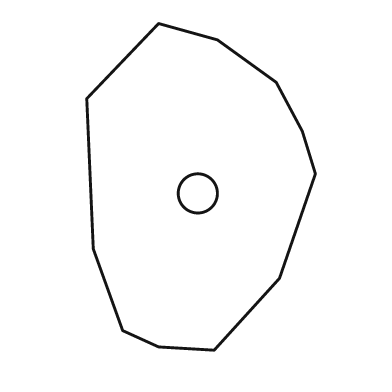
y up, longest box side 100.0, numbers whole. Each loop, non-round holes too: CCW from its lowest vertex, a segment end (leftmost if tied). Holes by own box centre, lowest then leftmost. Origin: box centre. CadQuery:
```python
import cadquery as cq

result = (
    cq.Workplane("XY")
    .moveTo(4.0, -50.0)
    .lineTo(24.0, -28.0)
    .lineTo(35.0, 4.0)
    .lineTo(31.0, 17.0)
    .lineTo(23.0, 32.0)
    .lineTo(5.0, 45.0)
    .lineTo(-13.0, 50.0)
    .lineTo(-35.0, 27.0)
    .lineTo(-33.0, -19.0)
    .lineTo(-24.0, -44.0)
    .lineTo(-13.0, -49.0)
    .close()
    .moveTo(-1.0, -2.0)
    .circle(6.0)
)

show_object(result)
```